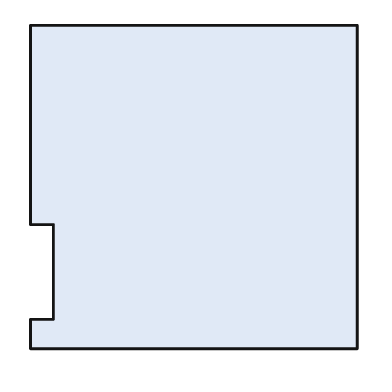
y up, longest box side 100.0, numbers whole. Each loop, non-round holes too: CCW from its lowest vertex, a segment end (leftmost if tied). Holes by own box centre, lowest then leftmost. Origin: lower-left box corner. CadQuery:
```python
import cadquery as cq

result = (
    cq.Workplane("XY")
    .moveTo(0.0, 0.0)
    .lineTo(100.0, 0.0)
    .lineTo(100.0, 99.0)
    .lineTo(0.0, 99.0)
    .lineTo(0.0, 38.0)
    .lineTo(7.0, 38.0)
    .lineTo(7.0, 9.0)
    .lineTo(0.0, 9.0)
    .close()
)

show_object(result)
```